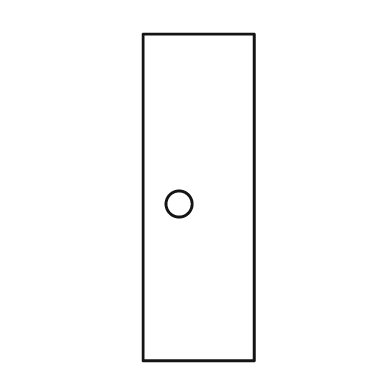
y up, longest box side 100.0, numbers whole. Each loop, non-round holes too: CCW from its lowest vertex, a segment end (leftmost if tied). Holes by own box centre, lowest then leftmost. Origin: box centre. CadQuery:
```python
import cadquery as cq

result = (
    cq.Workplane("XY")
    .moveTo(-17.0, -50.0)
    .lineTo(17.0, -50.0)
    .lineTo(17.0, 50.0)
    .lineTo(-17.0, 50.0)
    .close()
    .moveTo(-6.0, -2.0)
    .circle(4.0)
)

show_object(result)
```